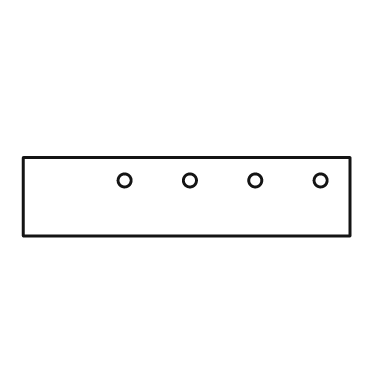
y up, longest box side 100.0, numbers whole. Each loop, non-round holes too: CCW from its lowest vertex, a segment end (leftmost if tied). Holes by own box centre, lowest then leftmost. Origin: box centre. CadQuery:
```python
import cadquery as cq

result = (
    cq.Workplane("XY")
    .moveTo(-50.0, -12.0)
    .lineTo(50.0, -12.0)
    .lineTo(50.0, 12.0)
    .lineTo(-50.0, 12.0)
    .close()
    .moveTo(-19.0, 5.0)
    .circle(2.0)
    .moveTo(1.0, 5.0)
    .circle(2.0)
    .moveTo(21.0, 5.0)
    .circle(2.0)
    .moveTo(41.0, 5.0)
    .circle(2.0)
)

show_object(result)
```